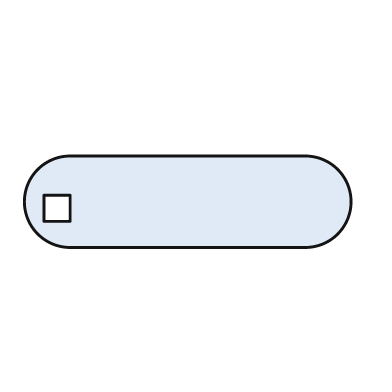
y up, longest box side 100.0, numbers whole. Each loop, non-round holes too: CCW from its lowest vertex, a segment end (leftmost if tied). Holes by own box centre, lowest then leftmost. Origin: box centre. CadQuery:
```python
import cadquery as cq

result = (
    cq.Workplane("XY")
    .moveTo(-36.0, -14.0)
    .lineTo(36.0, -14.0)
    .threePointArc((50.0, 0.0), (36.0, 14.0))
    .lineTo(-36.0, 14.0)
    .threePointArc((-50.0, 0.0), (-36.0, -14.0))
    .close()
    .moveTo(-44.0, -6.0)
    .lineTo(-36.0, -6.0)
    .lineTo(-36.0, 2.0)
    .lineTo(-44.0, 2.0)
    .close()
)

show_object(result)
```